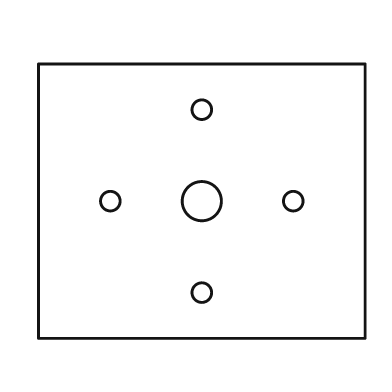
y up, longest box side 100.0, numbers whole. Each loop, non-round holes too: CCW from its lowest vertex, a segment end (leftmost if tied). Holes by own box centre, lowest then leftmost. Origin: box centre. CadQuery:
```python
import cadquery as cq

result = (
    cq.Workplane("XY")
    .moveTo(-50.0, -42.0)
    .lineTo(50.0, -42.0)
    .lineTo(50.0, 42.0)
    .lineTo(-50.0, 42.0)
    .close()
    .moveTo(0.0, -28.0)
    .circle(3.0)
    .moveTo(-28.0, 0.0)
    .circle(3.0)
    .moveTo(0.0, 0.0)
    .circle(6.0)
    .moveTo(28.0, 0.0)
    .circle(3.0)
    .moveTo(0.0, 28.0)
    .circle(3.0)
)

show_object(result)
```